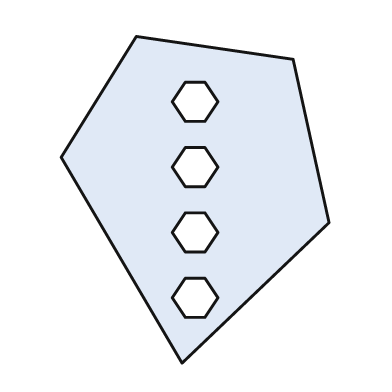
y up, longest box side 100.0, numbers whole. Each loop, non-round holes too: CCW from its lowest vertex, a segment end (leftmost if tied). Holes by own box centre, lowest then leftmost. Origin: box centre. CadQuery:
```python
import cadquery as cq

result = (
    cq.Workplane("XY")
    .moveTo(-4.0, -50.0)
    .lineTo(41.0, -7.0)
    .lineTo(30.0, 43.0)
    .lineTo(-18.0, 50.0)
    .lineTo(-41.0, 13.0)
    .close()
    .moveTo(-3.0, -36.0)
    .lineTo(3.0, -36.0)
    .lineTo(7.0, -30.0)
    .lineTo(3.0, -24.0)
    .lineTo(-3.0, -24.0)
    .lineTo(-7.0, -30.0)
    .close()
    .moveTo(-3.0, -16.0)
    .lineTo(3.0, -16.0)
    .lineTo(7.0, -10.0)
    .lineTo(3.0, -4.0)
    .lineTo(-3.0, -4.0)
    .lineTo(-7.0, -10.0)
    .close()
    .moveTo(-3.0, 4.0)
    .lineTo(3.0, 4.0)
    .lineTo(7.0, 10.0)
    .lineTo(3.0, 16.0)
    .lineTo(-3.0, 16.0)
    .lineTo(-7.0, 10.0)
    .close()
    .moveTo(-3.0, 24.0)
    .lineTo(3.0, 24.0)
    .lineTo(7.0, 30.0)
    .lineTo(3.0, 36.0)
    .lineTo(-3.0, 36.0)
    .lineTo(-7.0, 30.0)
    .close()
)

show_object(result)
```